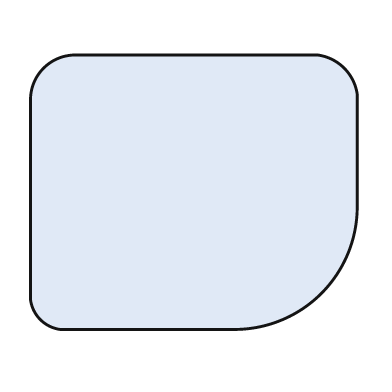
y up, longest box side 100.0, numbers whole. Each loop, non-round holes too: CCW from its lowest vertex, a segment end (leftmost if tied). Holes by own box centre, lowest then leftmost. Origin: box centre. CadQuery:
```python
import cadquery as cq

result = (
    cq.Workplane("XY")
    .moveTo(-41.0, -42.0)
    .lineTo(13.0, -42.0)
    .threePointArc((39.0, -31.0), (50.0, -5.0))
    .lineTo(50.0, 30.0)
    .threePointArc((46.0, 38.0), (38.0, 42.0))
    .lineTo(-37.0, 42.0)
    .threePointArc((-46.0, 38.0), (-50.0, 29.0))
    .lineTo(-50.0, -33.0)
    .threePointArc((-47.0, -39.0), (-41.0, -42.0))
    .close()
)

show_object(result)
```